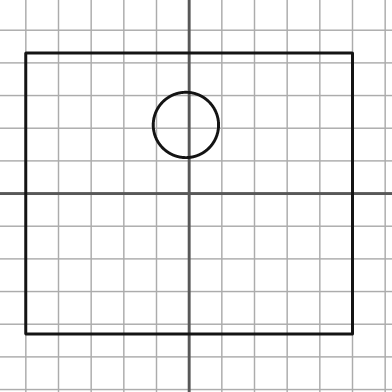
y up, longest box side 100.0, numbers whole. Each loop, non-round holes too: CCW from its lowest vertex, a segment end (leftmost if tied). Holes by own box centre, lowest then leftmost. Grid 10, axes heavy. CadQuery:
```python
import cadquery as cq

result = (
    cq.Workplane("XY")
    .moveTo(-50.0, -43.0)
    .lineTo(50.0, -43.0)
    .lineTo(50.0, 43.0)
    .lineTo(-50.0, 43.0)
    .close()
    .moveTo(-1.0, 21.0)
    .circle(10.0)
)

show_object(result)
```